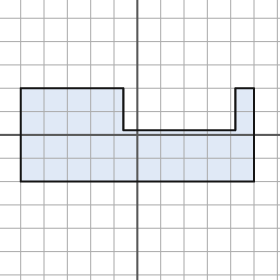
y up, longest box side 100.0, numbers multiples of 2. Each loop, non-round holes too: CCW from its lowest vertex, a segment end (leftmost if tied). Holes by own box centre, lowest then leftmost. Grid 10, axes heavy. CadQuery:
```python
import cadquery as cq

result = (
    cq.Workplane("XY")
    .moveTo(-50.0, -20.0)
    .lineTo(50.0, -20.0)
    .lineTo(50.0, 20.0)
    .lineTo(42.0, 20.0)
    .lineTo(42.0, 2.0)
    .lineTo(-6.0, 2.0)
    .lineTo(-6.0, 20.0)
    .lineTo(-50.0, 20.0)
    .close()
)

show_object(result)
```